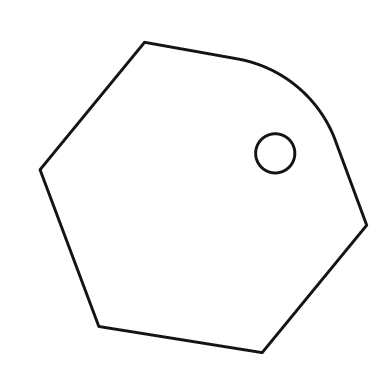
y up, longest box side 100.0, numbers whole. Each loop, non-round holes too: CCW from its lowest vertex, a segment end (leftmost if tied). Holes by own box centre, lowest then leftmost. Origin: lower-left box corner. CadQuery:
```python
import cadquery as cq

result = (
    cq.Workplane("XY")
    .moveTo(68.0, 0.0)
    .lineTo(100.0, 39.0)
    .lineTo(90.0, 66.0)
    .threePointArc((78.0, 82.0), (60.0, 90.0))
    .lineTo(32.0, 95.0)
    .lineTo(0.0, 56.0)
    .lineTo(18.0, 8.0)
    .close()
    .moveTo(72.0, 61.0)
    .circle(6.0)
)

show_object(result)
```